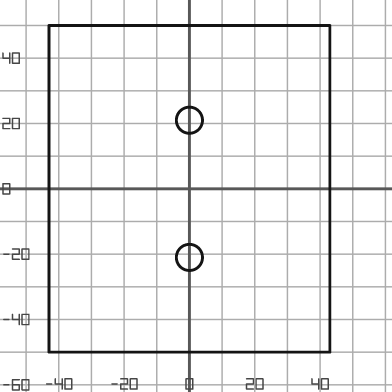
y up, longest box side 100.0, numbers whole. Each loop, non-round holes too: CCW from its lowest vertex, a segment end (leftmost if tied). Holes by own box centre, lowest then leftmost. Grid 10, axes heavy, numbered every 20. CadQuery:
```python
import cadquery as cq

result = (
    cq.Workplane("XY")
    .moveTo(-43.0, -50.0)
    .lineTo(43.0, -50.0)
    .lineTo(43.0, 50.0)
    .lineTo(-43.0, 50.0)
    .close()
    .moveTo(0.0, -21.0)
    .circle(4.0)
    .moveTo(0.0, 21.0)
    .circle(4.0)
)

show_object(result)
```